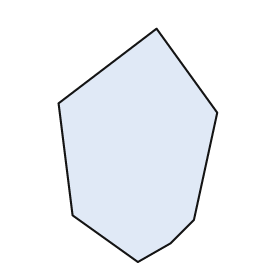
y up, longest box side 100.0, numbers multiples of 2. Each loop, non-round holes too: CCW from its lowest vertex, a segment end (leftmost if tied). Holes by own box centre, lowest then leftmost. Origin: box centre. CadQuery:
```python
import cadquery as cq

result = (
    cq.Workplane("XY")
    .moveTo(0.0, -50.0)
    .lineTo(14.0, -42.0)
    .lineTo(24.0, -32.0)
    .lineTo(34.0, 14.0)
    .lineTo(8.0, 50.0)
    .lineTo(-34.0, 18.0)
    .lineTo(-28.0, -30.0)
    .close()
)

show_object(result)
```